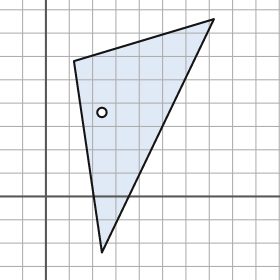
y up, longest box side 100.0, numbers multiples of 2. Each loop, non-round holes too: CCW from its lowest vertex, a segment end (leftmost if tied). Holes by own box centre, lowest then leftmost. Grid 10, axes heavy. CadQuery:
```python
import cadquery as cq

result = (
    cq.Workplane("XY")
    .moveTo(24.0, -24.0)
    .lineTo(72.0, 76.0)
    .lineTo(12.0, 58.0)
    .close()
    .moveTo(24.0, 36.0)
    .circle(2.0)
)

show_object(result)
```